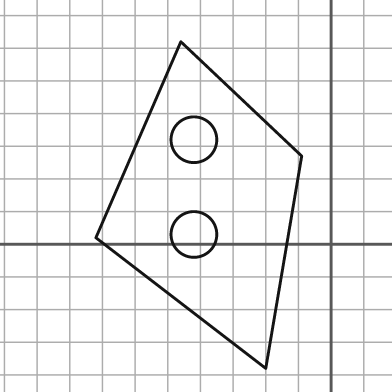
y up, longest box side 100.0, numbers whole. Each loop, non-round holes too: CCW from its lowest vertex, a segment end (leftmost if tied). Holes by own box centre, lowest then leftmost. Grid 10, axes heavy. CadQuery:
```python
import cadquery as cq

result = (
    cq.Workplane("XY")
    .moveTo(-20.0, -38.0)
    .lineTo(-9.0, 27.0)
    .lineTo(-46.0, 62.0)
    .lineTo(-72.0, 2.0)
    .close()
    .moveTo(-42.0, 3.0)
    .circle(7.0)
    .moveTo(-42.0, 32.0)
    .circle(7.0)
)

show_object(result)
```